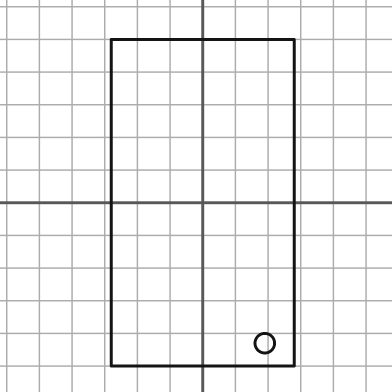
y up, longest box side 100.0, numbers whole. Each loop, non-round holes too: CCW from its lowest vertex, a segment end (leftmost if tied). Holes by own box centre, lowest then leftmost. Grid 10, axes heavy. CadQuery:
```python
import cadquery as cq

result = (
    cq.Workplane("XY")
    .moveTo(-28.0, -50.0)
    .lineTo(28.0, -50.0)
    .lineTo(28.0, 50.0)
    .lineTo(-28.0, 50.0)
    .close()
    .moveTo(19.0, -43.0)
    .circle(3.0)
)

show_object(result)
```